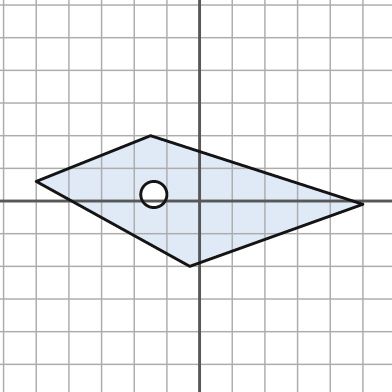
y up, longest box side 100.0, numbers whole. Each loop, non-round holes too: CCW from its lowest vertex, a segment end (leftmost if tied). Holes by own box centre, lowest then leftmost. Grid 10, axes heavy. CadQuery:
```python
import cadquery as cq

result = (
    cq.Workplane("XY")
    .moveTo(-3.0, -20.0)
    .lineTo(50.0, -1.0)
    .lineTo(-15.0, 20.0)
    .lineTo(-50.0, 6.0)
    .close()
    .moveTo(-14.0, 2.0)
    .circle(4.0)
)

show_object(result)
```